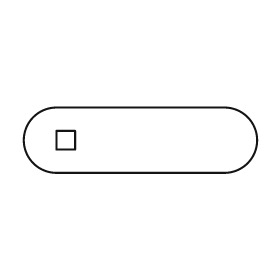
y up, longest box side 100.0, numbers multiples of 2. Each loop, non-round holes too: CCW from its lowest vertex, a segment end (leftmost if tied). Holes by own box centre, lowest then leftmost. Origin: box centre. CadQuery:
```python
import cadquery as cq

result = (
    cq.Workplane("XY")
    .moveTo(-36.0, -14.0)
    .lineTo(36.0, -14.0)
    .threePointArc((50.0, 0.0), (36.0, 14.0))
    .lineTo(-36.0, 14.0)
    .threePointArc((-50.0, 0.0), (-36.0, -14.0))
    .close()
    .moveTo(-36.0, -4.0)
    .lineTo(-28.0, -4.0)
    .lineTo(-28.0, 4.0)
    .lineTo(-36.0, 4.0)
    .close()
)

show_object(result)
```